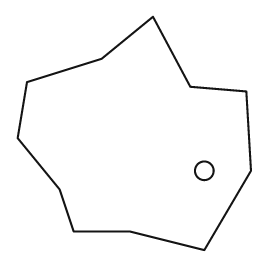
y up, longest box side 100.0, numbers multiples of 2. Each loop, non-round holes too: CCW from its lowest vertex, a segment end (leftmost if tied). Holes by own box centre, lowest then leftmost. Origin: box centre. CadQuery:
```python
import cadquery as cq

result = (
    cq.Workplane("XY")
    .moveTo(30.0, -50.0)
    .lineTo(50.0, -16.0)
    .lineTo(48.0, 18.0)
    .lineTo(24.0, 20.0)
    .lineTo(8.0, 50.0)
    .lineTo(-14.0, 32.0)
    .lineTo(-46.0, 22.0)
    .lineTo(-50.0, -2.0)
    .lineTo(-32.0, -24.0)
    .lineTo(-26.0, -42.0)
    .lineTo(-2.0, -42.0)
    .close()
    .moveTo(30.0, -16.0)
    .circle(4.0)
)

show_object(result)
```